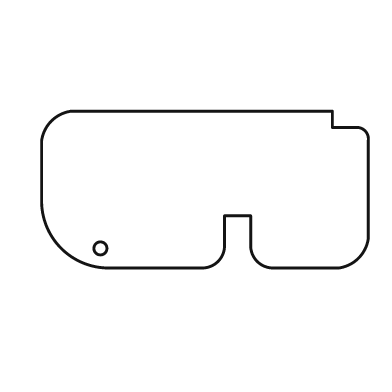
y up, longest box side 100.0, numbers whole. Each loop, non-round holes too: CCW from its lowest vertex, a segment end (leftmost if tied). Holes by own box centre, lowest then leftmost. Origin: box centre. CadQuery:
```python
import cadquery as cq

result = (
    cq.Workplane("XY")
    .moveTo(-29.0, -24.0)
    .lineTo(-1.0, -24.0)
    .threePointArc((4.0, -22.0), (6.0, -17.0))
    .lineTo(6.0, -8.0)
    .lineTo(14.0, -8.0)
    .lineTo(14.0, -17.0)
    .threePointArc((16.0, -22.0), (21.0, -24.0))
    .lineTo(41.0, -24.0)
    .threePointArc((47.0, -21.0), (50.0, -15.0))
    .lineTo(50.0, 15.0)
    .threePointArc((49.0, 18.0), (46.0, 19.0))
    .lineTo(39.0, 19.0)
    .lineTo(39.0, 24.0)
    .lineTo(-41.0, 24.0)
    .threePointArc((-47.0, 21.0), (-50.0, 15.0))
    .lineTo(-50.0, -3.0)
    .threePointArc((-44.0, -18.0), (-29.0, -24.0))
    .close()
    .moveTo(-32.0, -18.0)
    .circle(2.0)
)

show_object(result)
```